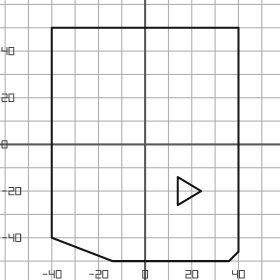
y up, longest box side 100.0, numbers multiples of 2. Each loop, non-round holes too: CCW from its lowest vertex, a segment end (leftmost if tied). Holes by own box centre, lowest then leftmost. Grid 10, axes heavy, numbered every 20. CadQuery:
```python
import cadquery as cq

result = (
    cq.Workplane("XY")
    .moveTo(-14.0, -50.0)
    .lineTo(36.0, -50.0)
    .lineTo(40.0, -46.0)
    .lineTo(40.0, 50.0)
    .lineTo(-40.0, 50.0)
    .lineTo(-40.0, -40.0)
    .close()
    .moveTo(14.0, -26.0)
    .lineTo(24.0, -20.0)
    .lineTo(14.0, -14.0)
    .close()
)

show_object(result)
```